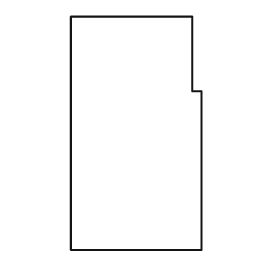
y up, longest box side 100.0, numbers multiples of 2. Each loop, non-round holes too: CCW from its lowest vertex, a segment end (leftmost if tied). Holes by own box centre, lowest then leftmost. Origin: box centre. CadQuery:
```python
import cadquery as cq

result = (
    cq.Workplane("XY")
    .moveTo(-28.0, -50.0)
    .lineTo(28.0, -50.0)
    .lineTo(28.0, 18.0)
    .lineTo(24.0, 18.0)
    .lineTo(24.0, 50.0)
    .lineTo(-28.0, 50.0)
    .close()
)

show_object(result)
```